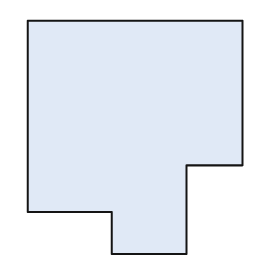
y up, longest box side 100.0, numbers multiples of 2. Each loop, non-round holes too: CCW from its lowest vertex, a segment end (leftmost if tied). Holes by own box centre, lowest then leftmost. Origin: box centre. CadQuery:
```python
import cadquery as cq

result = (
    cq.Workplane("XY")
    .moveTo(-10.0, -50.0)
    .lineTo(22.0, -50.0)
    .lineTo(22.0, -12.0)
    .lineTo(46.0, -12.0)
    .lineTo(46.0, 50.0)
    .lineTo(-46.0, 50.0)
    .lineTo(-46.0, -32.0)
    .lineTo(-10.0, -32.0)
    .close()
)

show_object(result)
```